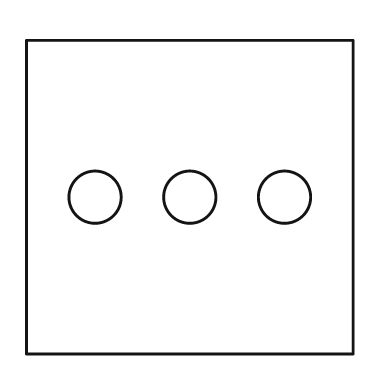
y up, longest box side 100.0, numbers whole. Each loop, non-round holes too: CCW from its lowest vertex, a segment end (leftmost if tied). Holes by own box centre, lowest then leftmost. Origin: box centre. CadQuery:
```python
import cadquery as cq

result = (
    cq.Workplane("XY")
    .moveTo(-50.0, -48.0)
    .lineTo(50.0, -48.0)
    .lineTo(50.0, 48.0)
    .lineTo(-50.0, 48.0)
    .close()
    .moveTo(-29.0, 0.0)
    .circle(8.0)
    .moveTo(0.0, 0.0)
    .circle(8.0)
    .moveTo(29.0, 0.0)
    .circle(8.0)
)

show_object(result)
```